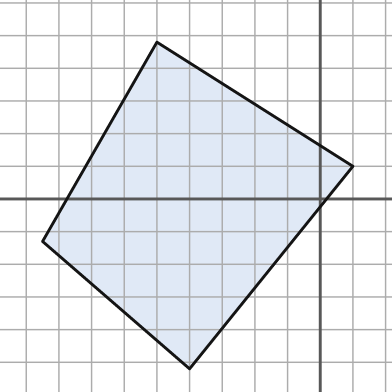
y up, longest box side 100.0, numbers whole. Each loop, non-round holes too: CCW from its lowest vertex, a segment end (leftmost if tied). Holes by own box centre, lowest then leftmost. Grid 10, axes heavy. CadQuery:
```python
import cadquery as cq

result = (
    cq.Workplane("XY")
    .moveTo(-40.0, -52.0)
    .lineTo(10.0, 10.0)
    .lineTo(-50.0, 48.0)
    .lineTo(-85.0, -13.0)
    .close()
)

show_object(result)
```